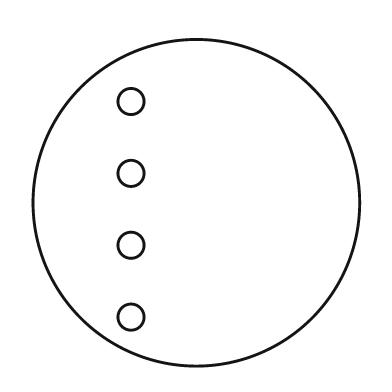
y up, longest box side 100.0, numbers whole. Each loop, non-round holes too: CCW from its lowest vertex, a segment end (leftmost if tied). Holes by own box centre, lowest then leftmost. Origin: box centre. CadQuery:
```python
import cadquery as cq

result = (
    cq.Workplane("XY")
    .moveTo(0.0, 0.0)
    .circle(50.0)
    .moveTo(-20.0, -35.0)
    .circle(4.0)
    .moveTo(-20.0, -13.0)
    .circle(4.0)
    .moveTo(-20.0, 9.0)
    .circle(4.0)
    .moveTo(-20.0, 31.0)
    .circle(4.0)
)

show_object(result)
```